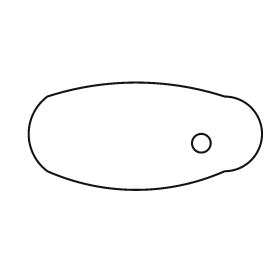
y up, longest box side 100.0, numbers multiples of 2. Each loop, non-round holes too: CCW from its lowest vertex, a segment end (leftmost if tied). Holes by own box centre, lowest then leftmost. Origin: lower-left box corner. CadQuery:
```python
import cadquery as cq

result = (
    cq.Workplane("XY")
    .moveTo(8.0, 8.0)
    .threePointArc((46.0, 0.0), (84.0, 8.0))
    .threePointArc((100.0, 24.0), (84.0, 40.0))
    .threePointArc((46.0, 46.0), (8.0, 40.0))
    .threePointArc((0.0, 24.0), (8.0, 8.0))
    .close()
    .moveTo(74.0, 20.0)
    .circle(4.0)
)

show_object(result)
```